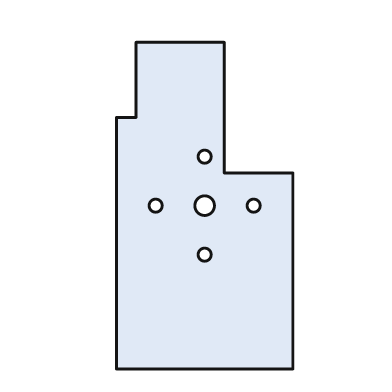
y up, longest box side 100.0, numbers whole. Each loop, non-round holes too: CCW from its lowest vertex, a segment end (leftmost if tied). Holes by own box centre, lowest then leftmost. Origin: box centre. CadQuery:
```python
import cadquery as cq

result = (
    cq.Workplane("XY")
    .moveTo(-27.0, -50.0)
    .lineTo(27.0, -50.0)
    .lineTo(27.0, 10.0)
    .lineTo(6.0, 10.0)
    .lineTo(6.0, 50.0)
    .lineTo(-21.0, 50.0)
    .lineTo(-21.0, 27.0)
    .lineTo(-27.0, 27.0)
    .close()
    .moveTo(0.0, -15.0)
    .circle(2.0)
    .moveTo(-15.0, 0.0)
    .circle(2.0)
    .moveTo(0.0, 0.0)
    .circle(3.0)
    .moveTo(15.0, 0.0)
    .circle(2.0)
    .moveTo(0.0, 15.0)
    .circle(2.0)
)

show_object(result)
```